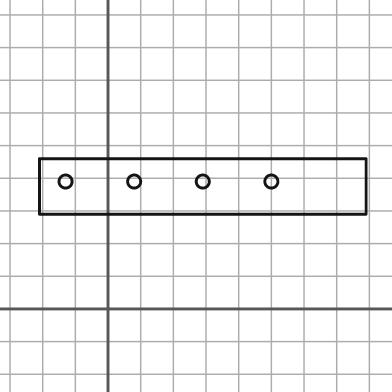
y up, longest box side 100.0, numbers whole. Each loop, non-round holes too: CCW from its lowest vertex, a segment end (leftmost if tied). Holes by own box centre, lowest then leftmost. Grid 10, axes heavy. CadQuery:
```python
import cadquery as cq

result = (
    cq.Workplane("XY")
    .moveTo(-21.0, 29.0)
    .lineTo(79.0, 29.0)
    .lineTo(79.0, 46.0)
    .lineTo(-21.0, 46.0)
    .close()
    .moveTo(-13.0, 39.0)
    .circle(2.0)
    .moveTo(8.0, 39.0)
    .circle(2.0)
    .moveTo(29.0, 39.0)
    .circle(2.0)
    .moveTo(50.0, 39.0)
    .circle(2.0)
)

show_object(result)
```